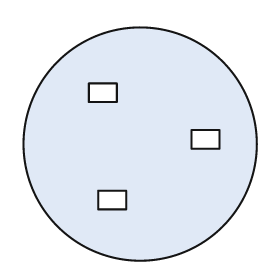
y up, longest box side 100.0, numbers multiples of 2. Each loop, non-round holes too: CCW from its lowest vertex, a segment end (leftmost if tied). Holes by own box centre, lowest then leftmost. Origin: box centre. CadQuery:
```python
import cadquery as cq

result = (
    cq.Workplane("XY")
    .moveTo(0.0, 0.0)
    .circle(50.0)
    .moveTo(-18.0, -28.0)
    .lineTo(-6.0, -28.0)
    .lineTo(-6.0, -20.0)
    .lineTo(-18.0, -20.0)
    .close()
    .moveTo(22.0, -2.0)
    .lineTo(34.0, -2.0)
    .lineTo(34.0, 6.0)
    .lineTo(22.0, 6.0)
    .close()
    .moveTo(-22.0, 18.0)
    .lineTo(-10.0, 18.0)
    .lineTo(-10.0, 26.0)
    .lineTo(-22.0, 26.0)
    .close()
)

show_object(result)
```